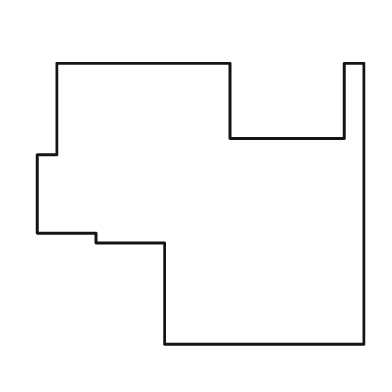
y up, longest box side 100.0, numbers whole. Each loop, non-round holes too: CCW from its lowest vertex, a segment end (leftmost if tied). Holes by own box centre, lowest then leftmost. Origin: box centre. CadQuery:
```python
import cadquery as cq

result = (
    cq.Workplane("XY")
    .moveTo(-11.0, -43.0)
    .lineTo(50.0, -43.0)
    .lineTo(50.0, 43.0)
    .lineTo(44.0, 43.0)
    .lineTo(44.0, 20.0)
    .lineTo(9.0, 20.0)
    .lineTo(9.0, 43.0)
    .lineTo(-44.0, 43.0)
    .lineTo(-44.0, 15.0)
    .lineTo(-50.0, 15.0)
    .lineTo(-50.0, -9.0)
    .lineTo(-32.0, -9.0)
    .lineTo(-32.0, -12.0)
    .lineTo(-11.0, -12.0)
    .close()
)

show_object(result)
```